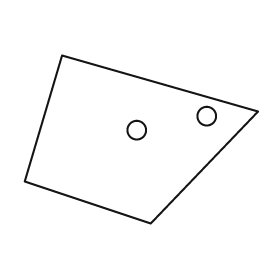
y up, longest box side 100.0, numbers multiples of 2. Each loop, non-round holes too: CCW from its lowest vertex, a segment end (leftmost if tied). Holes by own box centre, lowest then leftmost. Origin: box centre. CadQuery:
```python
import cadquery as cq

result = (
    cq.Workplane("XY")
    .moveTo(4.0, -36.0)
    .lineTo(50.0, 12.0)
    .lineTo(-34.0, 36.0)
    .lineTo(-50.0, -18.0)
    .close()
    .moveTo(-2.0, 4.0)
    .circle(4.0)
    .moveTo(28.0, 10.0)
    .circle(4.0)
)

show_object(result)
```